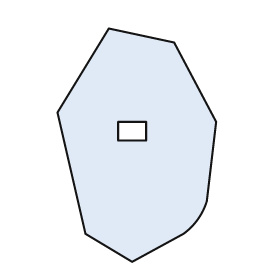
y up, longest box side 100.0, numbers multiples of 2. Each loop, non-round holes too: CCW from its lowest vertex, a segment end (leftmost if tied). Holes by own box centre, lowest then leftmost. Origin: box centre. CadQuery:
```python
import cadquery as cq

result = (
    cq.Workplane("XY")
    .moveTo(-2.0, -50.0)
    .lineTo(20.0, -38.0)
    .threePointArc((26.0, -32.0), (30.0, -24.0))
    .lineTo(34.0, 10.0)
    .lineTo(16.0, 44.0)
    .lineTo(-12.0, 50.0)
    .lineTo(-34.0, 14.0)
    .lineTo(-22.0, -38.0)
    .close()
    .moveTo(-8.0, 2.0)
    .lineTo(4.0, 2.0)
    .lineTo(4.0, 10.0)
    .lineTo(-8.0, 10.0)
    .close()
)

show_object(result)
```